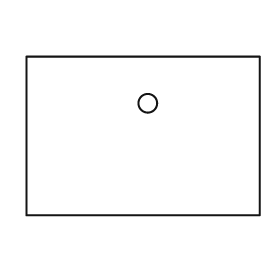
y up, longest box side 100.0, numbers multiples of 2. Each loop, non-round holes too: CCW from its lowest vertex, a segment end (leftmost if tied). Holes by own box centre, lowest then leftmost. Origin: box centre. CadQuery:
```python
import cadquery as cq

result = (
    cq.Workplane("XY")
    .moveTo(-50.0, -34.0)
    .lineTo(50.0, -34.0)
    .lineTo(50.0, 34.0)
    .lineTo(-50.0, 34.0)
    .close()
    .moveTo(2.0, 14.0)
    .circle(4.0)
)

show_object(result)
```